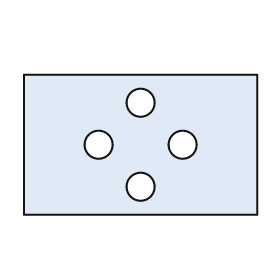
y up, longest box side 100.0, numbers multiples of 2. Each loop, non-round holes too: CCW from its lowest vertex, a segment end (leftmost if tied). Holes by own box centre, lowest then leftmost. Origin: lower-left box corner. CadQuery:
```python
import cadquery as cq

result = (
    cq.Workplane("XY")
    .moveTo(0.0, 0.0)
    .lineTo(100.0, 0.0)
    .lineTo(100.0, 60.0)
    .lineTo(0.0, 60.0)
    .close()
    .moveTo(50.0, 12.0)
    .circle(6.0)
    .moveTo(32.0, 30.0)
    .circle(6.0)
    .moveTo(68.0, 30.0)
    .circle(6.0)
    .moveTo(50.0, 48.0)
    .circle(6.0)
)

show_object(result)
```